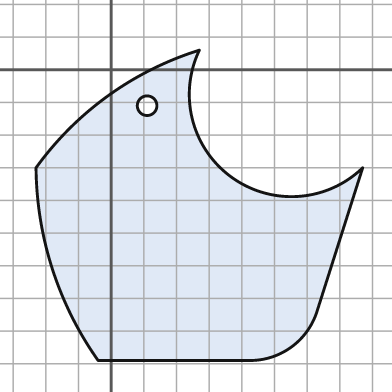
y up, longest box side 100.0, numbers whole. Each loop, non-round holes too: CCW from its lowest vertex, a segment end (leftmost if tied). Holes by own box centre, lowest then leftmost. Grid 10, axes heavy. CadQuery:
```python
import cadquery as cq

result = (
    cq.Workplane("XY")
    .moveTo(-4.0, -89.0)
    .lineTo(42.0, -89.0)
    .threePointArc((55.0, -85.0), (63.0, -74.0))
    .lineTo(77.0, -30.0)
    .threePointArc((37.0, -33.0), (27.0, 6.0))
    .threePointArc((-1.0, -8.0), (-23.0, -30.0))
    .threePointArc((-18.0, -61.0), (-4.0, -89.0))
    .close()
    .moveTo(11.0, -11.0)
    .circle(3.0)
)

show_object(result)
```